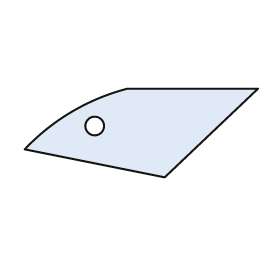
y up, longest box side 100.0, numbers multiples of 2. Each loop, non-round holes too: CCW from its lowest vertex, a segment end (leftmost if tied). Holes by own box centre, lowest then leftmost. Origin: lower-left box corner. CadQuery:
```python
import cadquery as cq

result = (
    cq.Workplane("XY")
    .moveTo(60.0, 0.0)
    .lineTo(100.0, 38.0)
    .lineTo(44.0, 38.0)
    .threePointArc((20.0, 28.0), (0.0, 12.0))
    .close()
    .moveTo(30.0, 22.0)
    .circle(4.0)
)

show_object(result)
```